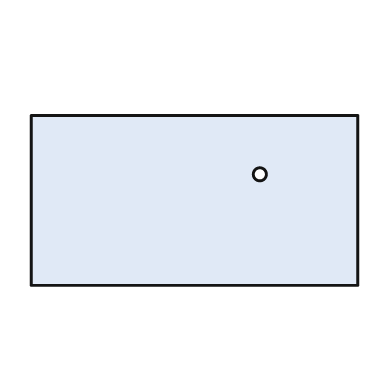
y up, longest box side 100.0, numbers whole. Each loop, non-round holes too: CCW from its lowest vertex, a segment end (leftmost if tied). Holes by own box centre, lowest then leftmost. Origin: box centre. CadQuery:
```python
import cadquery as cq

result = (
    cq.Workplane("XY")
    .moveTo(-50.0, -26.0)
    .lineTo(50.0, -26.0)
    .lineTo(50.0, 26.0)
    .lineTo(-50.0, 26.0)
    .close()
    .moveTo(20.0, 8.0)
    .circle(2.0)
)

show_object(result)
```